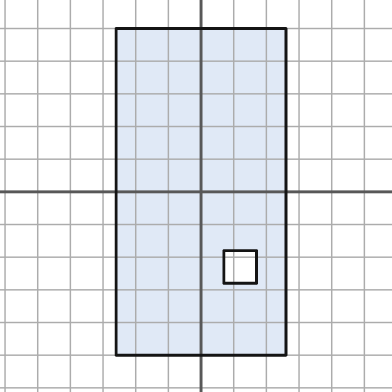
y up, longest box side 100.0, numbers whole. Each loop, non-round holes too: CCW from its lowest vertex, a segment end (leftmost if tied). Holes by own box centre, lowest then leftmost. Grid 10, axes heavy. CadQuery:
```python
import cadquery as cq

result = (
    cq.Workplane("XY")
    .moveTo(-26.0, -50.0)
    .lineTo(26.0, -50.0)
    .lineTo(26.0, 50.0)
    .lineTo(-26.0, 50.0)
    .close()
    .moveTo(7.0, -28.0)
    .lineTo(17.0, -28.0)
    .lineTo(17.0, -18.0)
    .lineTo(7.0, -18.0)
    .close()
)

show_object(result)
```